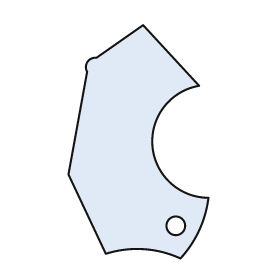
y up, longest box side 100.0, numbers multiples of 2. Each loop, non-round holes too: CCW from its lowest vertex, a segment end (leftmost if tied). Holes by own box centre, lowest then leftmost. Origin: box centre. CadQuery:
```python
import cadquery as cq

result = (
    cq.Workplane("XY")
    .moveTo(18.0, -50.0)
    .threePointArc((26.0, -38.0), (30.0, -24.0))
    .threePointArc((6.0, -2.0), (26.0, 24.0))
    .lineTo(2.0, 50.0)
    .lineTo(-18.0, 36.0)
    .threePointArc((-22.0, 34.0), (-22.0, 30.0))
    .lineTo(-30.0, -14.0)
    .lineTo(-14.0, -48.0)
    .threePointArc((2.0, -46.0), (18.0, -50.0))
    .close()
    .moveTo(16.0, -36.0)
    .circle(4.0)
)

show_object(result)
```